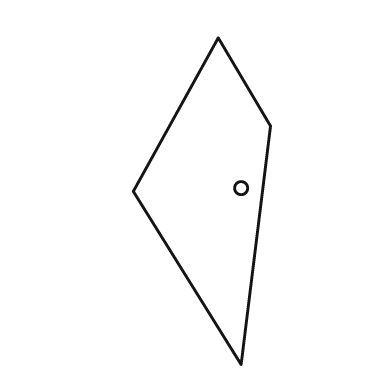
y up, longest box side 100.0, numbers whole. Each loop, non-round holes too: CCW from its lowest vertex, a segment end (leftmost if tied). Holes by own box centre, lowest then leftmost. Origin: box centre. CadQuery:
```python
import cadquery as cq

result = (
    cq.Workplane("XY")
    .moveTo(12.0, -50.0)
    .lineTo(21.0, 23.0)
    .lineTo(5.0, 50.0)
    .lineTo(-21.0, 3.0)
    .close()
    .moveTo(12.0, 4.0)
    .circle(2.0)
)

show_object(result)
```